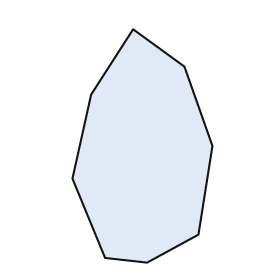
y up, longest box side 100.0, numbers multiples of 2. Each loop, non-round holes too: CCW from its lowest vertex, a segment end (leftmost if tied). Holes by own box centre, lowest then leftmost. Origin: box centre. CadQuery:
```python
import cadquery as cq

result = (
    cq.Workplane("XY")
    .moveTo(2.0, -50.0)
    .lineTo(24.0, -38.0)
    .lineTo(30.0, 0.0)
    .lineTo(18.0, 34.0)
    .lineTo(-4.0, 50.0)
    .lineTo(-22.0, 22.0)
    .lineTo(-30.0, -14.0)
    .lineTo(-16.0, -48.0)
    .close()
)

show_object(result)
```